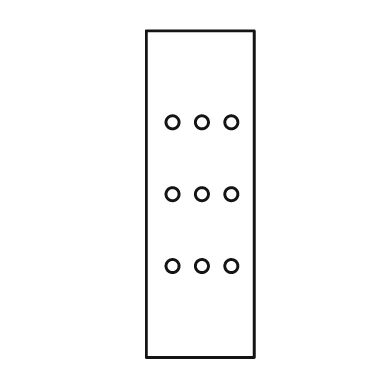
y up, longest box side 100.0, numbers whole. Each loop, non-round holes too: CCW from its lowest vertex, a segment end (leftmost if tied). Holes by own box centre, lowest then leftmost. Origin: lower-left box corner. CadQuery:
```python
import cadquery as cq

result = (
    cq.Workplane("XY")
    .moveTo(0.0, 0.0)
    .lineTo(33.0, 0.0)
    .lineTo(33.0, 100.0)
    .lineTo(0.0, 100.0)
    .close()
    .moveTo(8.0, 28.0)
    .circle(2.0)
    .moveTo(17.0, 28.0)
    .circle(2.0)
    .moveTo(26.0, 28.0)
    .circle(2.0)
    .moveTo(8.0, 50.0)
    .circle(2.0)
    .moveTo(17.0, 50.0)
    .circle(2.0)
    .moveTo(26.0, 50.0)
    .circle(2.0)
    .moveTo(8.0, 72.0)
    .circle(2.0)
    .moveTo(17.0, 72.0)
    .circle(2.0)
    .moveTo(26.0, 72.0)
    .circle(2.0)
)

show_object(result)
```